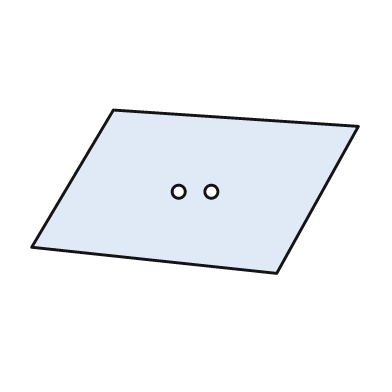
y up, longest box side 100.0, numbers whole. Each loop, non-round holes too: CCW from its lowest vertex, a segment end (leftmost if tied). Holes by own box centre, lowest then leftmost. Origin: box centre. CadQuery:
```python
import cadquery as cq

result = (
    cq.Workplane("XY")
    .moveTo(25.0, -25.0)
    .lineTo(50.0, 20.0)
    .lineTo(-25.0, 25.0)
    .lineTo(-50.0, -17.0)
    .close()
    .moveTo(-5.0, 0.0)
    .circle(2.0)
    .moveTo(5.0, 0.0)
    .circle(2.0)
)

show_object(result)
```